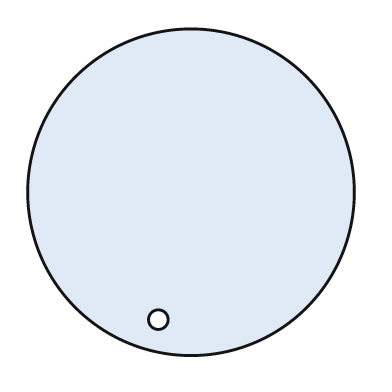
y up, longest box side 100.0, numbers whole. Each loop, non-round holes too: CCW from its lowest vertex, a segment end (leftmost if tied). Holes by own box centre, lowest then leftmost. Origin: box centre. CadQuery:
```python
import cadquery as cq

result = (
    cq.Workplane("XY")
    .moveTo(0.0, 0.0)
    .circle(50.0)
    .moveTo(-10.0, -39.0)
    .circle(3.0)
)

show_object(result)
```